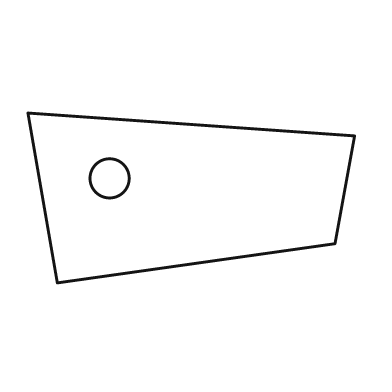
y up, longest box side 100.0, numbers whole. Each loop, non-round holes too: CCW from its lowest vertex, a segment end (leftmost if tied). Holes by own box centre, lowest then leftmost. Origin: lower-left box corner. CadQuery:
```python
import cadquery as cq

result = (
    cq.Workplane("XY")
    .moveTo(9.0, 0.0)
    .lineTo(94.0, 12.0)
    .lineTo(100.0, 45.0)
    .lineTo(0.0, 52.0)
    .close()
    .moveTo(25.0, 32.0)
    .circle(6.0)
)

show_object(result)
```